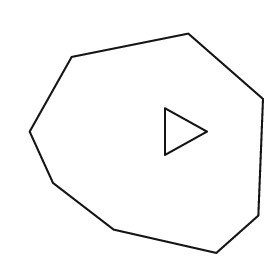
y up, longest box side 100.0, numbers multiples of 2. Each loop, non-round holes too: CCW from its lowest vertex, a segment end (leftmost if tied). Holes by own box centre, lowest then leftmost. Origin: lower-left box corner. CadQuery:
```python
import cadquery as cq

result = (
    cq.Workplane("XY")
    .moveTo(80.0, 0.0)
    .lineTo(98.0, 16.0)
    .lineTo(100.0, 66.0)
    .lineTo(68.0, 94.0)
    .lineTo(18.0, 84.0)
    .lineTo(0.0, 52.0)
    .lineTo(10.0, 30.0)
    .lineTo(36.0, 10.0)
    .close()
    .moveTo(58.0, 42.0)
    .lineTo(76.0, 52.0)
    .lineTo(58.0, 62.0)
    .close()
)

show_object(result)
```